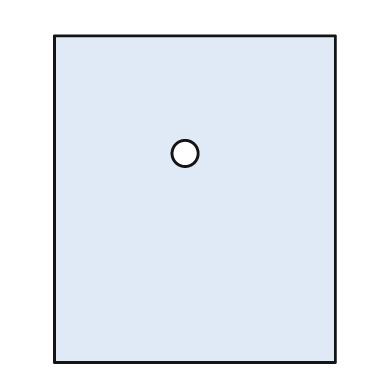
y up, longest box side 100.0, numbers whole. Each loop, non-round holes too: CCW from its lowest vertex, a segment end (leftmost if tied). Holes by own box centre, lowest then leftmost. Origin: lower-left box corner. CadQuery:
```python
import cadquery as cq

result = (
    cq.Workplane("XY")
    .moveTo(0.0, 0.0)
    .lineTo(86.0, 0.0)
    .lineTo(86.0, 100.0)
    .lineTo(0.0, 100.0)
    .close()
    .moveTo(40.0, 64.0)
    .circle(4.0)
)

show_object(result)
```